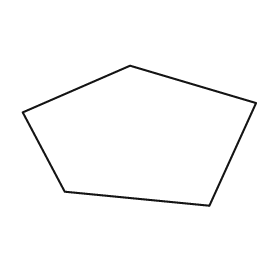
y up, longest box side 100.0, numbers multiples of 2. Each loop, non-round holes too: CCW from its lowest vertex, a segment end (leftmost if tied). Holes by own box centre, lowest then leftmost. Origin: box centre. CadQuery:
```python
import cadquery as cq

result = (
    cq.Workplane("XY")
    .moveTo(30.0, -30.0)
    .lineTo(50.0, 14.0)
    .lineTo(-4.0, 30.0)
    .lineTo(-50.0, 10.0)
    .lineTo(-32.0, -24.0)
    .close()
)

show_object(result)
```